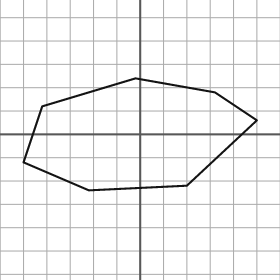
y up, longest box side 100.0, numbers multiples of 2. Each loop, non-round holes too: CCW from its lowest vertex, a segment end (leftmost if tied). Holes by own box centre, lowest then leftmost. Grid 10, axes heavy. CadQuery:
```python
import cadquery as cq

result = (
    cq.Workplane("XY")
    .moveTo(-22.0, -24.0)
    .lineTo(20.0, -22.0)
    .lineTo(50.0, 6.0)
    .lineTo(32.0, 18.0)
    .lineTo(-2.0, 24.0)
    .lineTo(-42.0, 12.0)
    .lineTo(-50.0, -12.0)
    .close()
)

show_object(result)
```